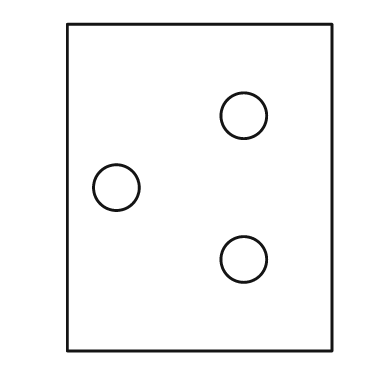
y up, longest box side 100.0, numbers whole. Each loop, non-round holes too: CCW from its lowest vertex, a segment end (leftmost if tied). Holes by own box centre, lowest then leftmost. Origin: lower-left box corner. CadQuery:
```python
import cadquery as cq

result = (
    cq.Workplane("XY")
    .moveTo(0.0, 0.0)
    .lineTo(81.0, 0.0)
    .lineTo(81.0, 100.0)
    .lineTo(0.0, 100.0)
    .close()
    .moveTo(54.0, 28.0)
    .circle(7.0)
    .moveTo(15.0, 50.0)
    .circle(7.0)
    .moveTo(54.0, 72.0)
    .circle(7.0)
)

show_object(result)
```